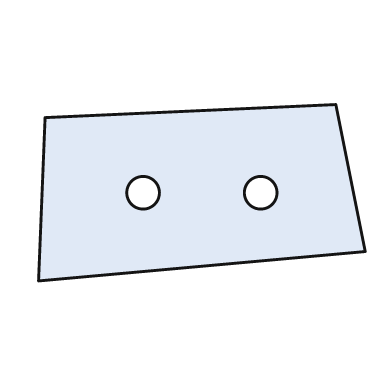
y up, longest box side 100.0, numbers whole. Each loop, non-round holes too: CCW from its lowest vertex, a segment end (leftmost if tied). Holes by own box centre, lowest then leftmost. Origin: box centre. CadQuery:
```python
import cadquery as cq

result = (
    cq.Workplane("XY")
    .moveTo(-50.0, -27.0)
    .lineTo(50.0, -18.0)
    .lineTo(41.0, 27.0)
    .lineTo(-48.0, 23.0)
    .close()
    .moveTo(-18.0, 0.0)
    .circle(5.0)
    .moveTo(18.0, 0.0)
    .circle(5.0)
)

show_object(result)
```